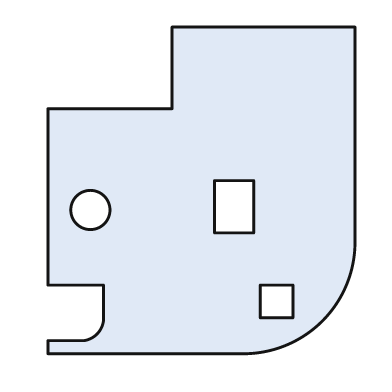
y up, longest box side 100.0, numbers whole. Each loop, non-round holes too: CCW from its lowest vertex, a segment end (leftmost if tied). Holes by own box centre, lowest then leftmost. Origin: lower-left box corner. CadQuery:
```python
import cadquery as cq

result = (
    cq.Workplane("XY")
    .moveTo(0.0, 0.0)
    .lineTo(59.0, 0.0)
    .threePointArc((84.0, 10.0), (94.0, 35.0))
    .lineTo(94.0, 100.0)
    .lineTo(38.0, 100.0)
    .lineTo(38.0, 75.0)
    .lineTo(0.0, 75.0)
    .lineTo(0.0, 21.0)
    .lineTo(17.0, 21.0)
    .lineTo(17.0, 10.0)
    .threePointArc((15.0, 6.0), (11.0, 4.0))
    .lineTo(0.0, 4.0)
    .close()
    .moveTo(65.0, 11.0)
    .lineTo(75.0, 11.0)
    .lineTo(75.0, 21.0)
    .lineTo(65.0, 21.0)
    .close()
    .moveTo(13.0, 44.0)
    .circle(6.0)
    .moveTo(51.0, 37.0)
    .lineTo(63.0, 37.0)
    .lineTo(63.0, 53.0)
    .lineTo(51.0, 53.0)
    .close()
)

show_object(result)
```